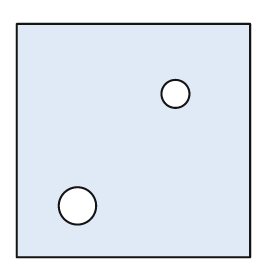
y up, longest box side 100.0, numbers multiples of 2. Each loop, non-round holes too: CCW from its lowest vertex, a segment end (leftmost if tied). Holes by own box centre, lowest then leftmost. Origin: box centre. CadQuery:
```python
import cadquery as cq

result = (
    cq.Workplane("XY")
    .moveTo(-50.0, -50.0)
    .lineTo(50.0, -50.0)
    .lineTo(50.0, 50.0)
    .lineTo(-50.0, 50.0)
    .close()
    .moveTo(-24.0, -28.0)
    .circle(8.0)
    .moveTo(18.0, 20.0)
    .circle(6.0)
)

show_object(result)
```